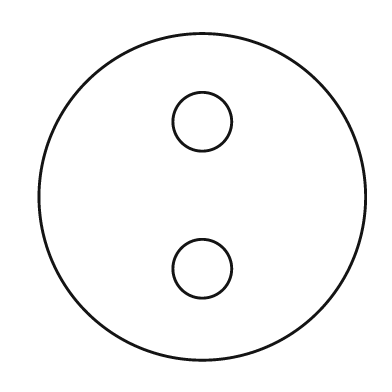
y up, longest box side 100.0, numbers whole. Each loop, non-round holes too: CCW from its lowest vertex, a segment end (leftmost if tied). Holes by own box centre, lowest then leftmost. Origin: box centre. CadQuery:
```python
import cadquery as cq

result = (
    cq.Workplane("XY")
    .moveTo(0.0, 0.0)
    .circle(50.0)
    .moveTo(0.0, -22.0)
    .circle(9.0)
    .moveTo(0.0, 23.0)
    .circle(9.0)
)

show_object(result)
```